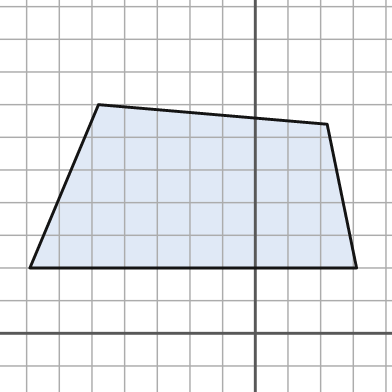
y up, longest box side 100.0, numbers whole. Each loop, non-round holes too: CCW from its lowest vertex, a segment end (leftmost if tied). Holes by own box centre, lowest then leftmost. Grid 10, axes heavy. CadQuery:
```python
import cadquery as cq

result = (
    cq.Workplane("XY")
    .moveTo(-69.0, 20.0)
    .lineTo(31.0, 20.0)
    .lineTo(22.0, 64.0)
    .lineTo(-48.0, 70.0)
    .close()
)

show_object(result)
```